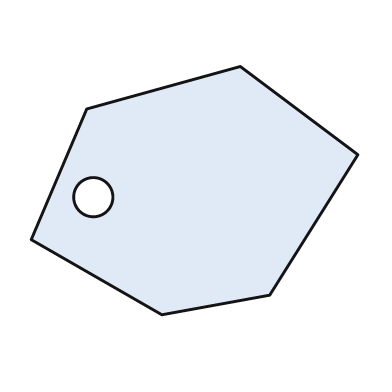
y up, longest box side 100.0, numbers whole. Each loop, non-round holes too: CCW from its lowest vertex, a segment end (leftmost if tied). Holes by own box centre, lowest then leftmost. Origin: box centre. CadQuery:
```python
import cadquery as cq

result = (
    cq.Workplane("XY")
    .moveTo(-10.0, -38.0)
    .lineTo(23.0, -32.0)
    .lineTo(50.0, 11.0)
    .lineTo(14.0, 38.0)
    .lineTo(-33.0, 25.0)
    .lineTo(-50.0, -15.0)
    .close()
    .moveTo(-31.0, -2.0)
    .circle(6.0)
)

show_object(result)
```